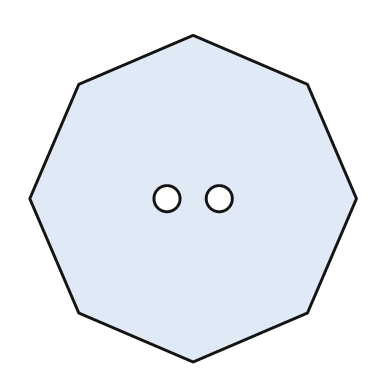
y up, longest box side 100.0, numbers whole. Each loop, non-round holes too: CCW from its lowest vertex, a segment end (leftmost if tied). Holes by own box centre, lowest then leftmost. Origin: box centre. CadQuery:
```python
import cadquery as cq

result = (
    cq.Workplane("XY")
    .moveTo(0.0, -50.0)
    .lineTo(35.0, -35.0)
    .lineTo(50.0, 0.0)
    .lineTo(35.0, 35.0)
    .lineTo(0.0, 50.0)
    .lineTo(-35.0, 35.0)
    .lineTo(-50.0, 0.0)
    .lineTo(-35.0, -35.0)
    .close()
    .moveTo(-8.0, 0.0)
    .circle(4.0)
    .moveTo(8.0, 0.0)
    .circle(4.0)
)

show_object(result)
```